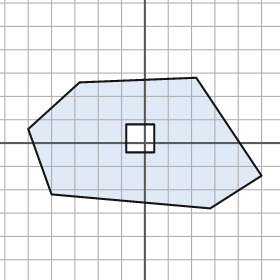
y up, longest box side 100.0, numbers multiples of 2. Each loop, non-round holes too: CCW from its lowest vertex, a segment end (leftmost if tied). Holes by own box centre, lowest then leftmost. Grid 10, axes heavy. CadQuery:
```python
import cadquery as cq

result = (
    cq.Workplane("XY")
    .moveTo(28.0, -28.0)
    .lineTo(50.0, -14.0)
    .lineTo(22.0, 28.0)
    .lineTo(-28.0, 26.0)
    .lineTo(-50.0, 6.0)
    .lineTo(-40.0, -22.0)
    .close()
    .moveTo(-8.0, -4.0)
    .lineTo(4.0, -4.0)
    .lineTo(4.0, 8.0)
    .lineTo(-8.0, 8.0)
    .close()
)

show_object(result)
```